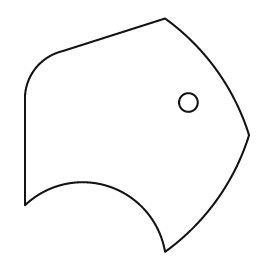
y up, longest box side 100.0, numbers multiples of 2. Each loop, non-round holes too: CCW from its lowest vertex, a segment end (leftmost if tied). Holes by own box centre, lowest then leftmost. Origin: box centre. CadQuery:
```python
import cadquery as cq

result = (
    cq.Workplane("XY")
    .moveTo(12.0, -50.0)
    .threePointArc((34.0, -28.0), (48.0, 0.0))
    .threePointArc((34.0, 28.0), (12.0, 50.0))
    .lineTo(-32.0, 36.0)
    .threePointArc((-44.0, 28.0), (-48.0, 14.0))
    .lineTo(-48.0, -30.0)
    .threePointArc((-12.0, -22.0), (12.0, -50.0))
    .close()
    .moveTo(22.0, 14.0)
    .circle(4.0)
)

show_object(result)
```